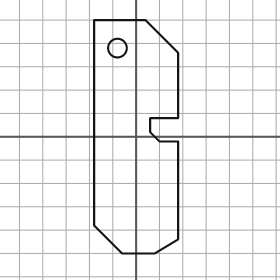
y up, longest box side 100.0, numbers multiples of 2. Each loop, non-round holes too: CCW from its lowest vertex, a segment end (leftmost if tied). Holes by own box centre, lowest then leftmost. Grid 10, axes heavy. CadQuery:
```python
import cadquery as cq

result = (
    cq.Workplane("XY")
    .moveTo(-6.0, -50.0)
    .lineTo(8.0, -50.0)
    .lineTo(18.0, -44.0)
    .lineTo(18.0, -2.0)
    .lineTo(10.0, -2.0)
    .lineTo(6.0, 2.0)
    .lineTo(6.0, 8.0)
    .lineTo(18.0, 8.0)
    .lineTo(18.0, 36.0)
    .lineTo(4.0, 50.0)
    .lineTo(-18.0, 50.0)
    .lineTo(-18.0, -38.0)
    .close()
    .moveTo(-8.0, 38.0)
    .circle(4.0)
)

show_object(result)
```